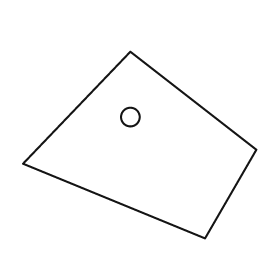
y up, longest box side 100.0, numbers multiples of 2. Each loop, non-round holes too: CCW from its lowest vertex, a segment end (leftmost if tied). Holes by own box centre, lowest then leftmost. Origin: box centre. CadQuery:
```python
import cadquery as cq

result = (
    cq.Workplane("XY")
    .moveTo(28.0, -40.0)
    .lineTo(50.0, -2.0)
    .lineTo(-4.0, 40.0)
    .lineTo(-50.0, -8.0)
    .close()
    .moveTo(-4.0, 12.0)
    .circle(4.0)
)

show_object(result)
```